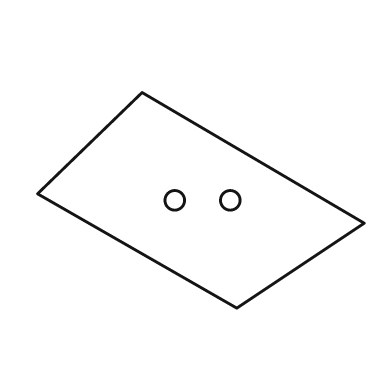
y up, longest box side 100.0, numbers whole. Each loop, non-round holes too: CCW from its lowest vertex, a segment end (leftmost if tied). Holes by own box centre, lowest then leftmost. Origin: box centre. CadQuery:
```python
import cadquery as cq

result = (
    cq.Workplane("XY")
    .moveTo(11.0, -33.0)
    .lineTo(50.0, -7.0)
    .lineTo(-18.0, 33.0)
    .lineTo(-50.0, 2.0)
    .close()
    .moveTo(-8.0, 0.0)
    .circle(3.0)
    .moveTo(9.0, 0.0)
    .circle(3.0)
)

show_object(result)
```